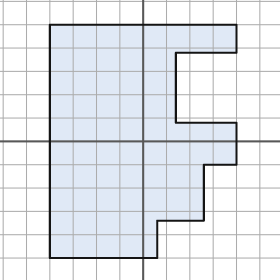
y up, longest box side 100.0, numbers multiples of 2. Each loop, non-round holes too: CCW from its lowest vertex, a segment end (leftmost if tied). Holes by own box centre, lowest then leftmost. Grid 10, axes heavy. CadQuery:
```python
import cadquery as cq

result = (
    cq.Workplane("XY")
    .moveTo(-40.0, -50.0)
    .lineTo(6.0, -50.0)
    .lineTo(6.0, -34.0)
    .lineTo(26.0, -34.0)
    .lineTo(26.0, -10.0)
    .lineTo(40.0, -10.0)
    .lineTo(40.0, 8.0)
    .lineTo(14.0, 8.0)
    .lineTo(14.0, 38.0)
    .lineTo(40.0, 38.0)
    .lineTo(40.0, 50.0)
    .lineTo(-40.0, 50.0)
    .close()
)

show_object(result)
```